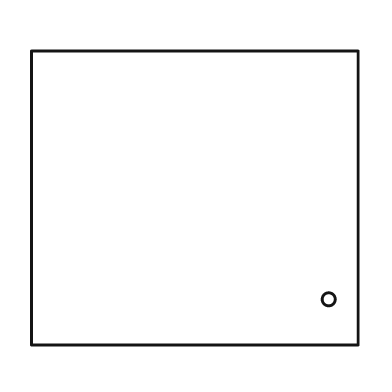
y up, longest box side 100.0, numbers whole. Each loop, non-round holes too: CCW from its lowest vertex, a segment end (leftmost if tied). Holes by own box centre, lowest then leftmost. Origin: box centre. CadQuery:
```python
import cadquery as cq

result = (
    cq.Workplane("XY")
    .moveTo(-50.0, -45.0)
    .lineTo(50.0, -45.0)
    .lineTo(50.0, 45.0)
    .lineTo(-50.0, 45.0)
    .close()
    .moveTo(41.0, -31.0)
    .circle(2.0)
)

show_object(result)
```